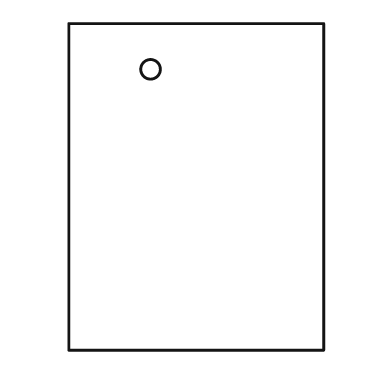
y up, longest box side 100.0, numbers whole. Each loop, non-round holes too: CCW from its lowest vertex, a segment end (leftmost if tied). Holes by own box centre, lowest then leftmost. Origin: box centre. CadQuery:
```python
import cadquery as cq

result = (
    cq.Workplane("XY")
    .moveTo(-39.0, -50.0)
    .lineTo(39.0, -50.0)
    .lineTo(39.0, 50.0)
    .lineTo(-39.0, 50.0)
    .close()
    .moveTo(-14.0, 36.0)
    .circle(3.0)
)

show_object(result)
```